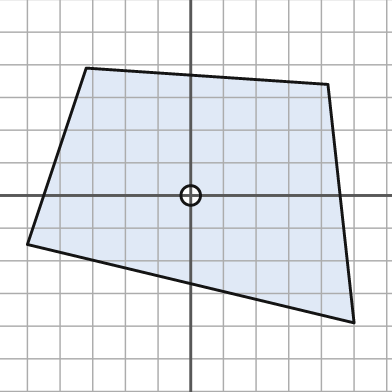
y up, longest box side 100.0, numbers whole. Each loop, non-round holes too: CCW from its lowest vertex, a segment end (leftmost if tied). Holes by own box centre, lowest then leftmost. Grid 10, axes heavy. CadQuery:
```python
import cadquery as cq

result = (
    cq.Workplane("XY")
    .moveTo(50.0, -39.0)
    .lineTo(42.0, 34.0)
    .lineTo(-32.0, 39.0)
    .lineTo(-50.0, -15.0)
    .close()
    .moveTo(0.0, 0.0)
    .circle(3.0)
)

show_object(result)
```